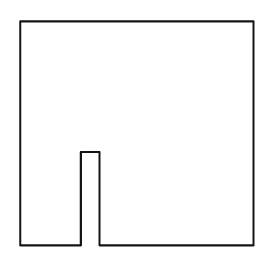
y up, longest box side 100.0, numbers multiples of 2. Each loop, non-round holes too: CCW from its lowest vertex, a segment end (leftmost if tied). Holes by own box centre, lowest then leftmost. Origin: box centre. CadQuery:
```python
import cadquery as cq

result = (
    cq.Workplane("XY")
    .moveTo(-50.0, -48.0)
    .lineTo(-24.0, -48.0)
    .lineTo(-24.0, -8.0)
    .lineTo(-16.0, -8.0)
    .lineTo(-16.0, -48.0)
    .lineTo(50.0, -48.0)
    .lineTo(50.0, 48.0)
    .lineTo(-50.0, 48.0)
    .close()
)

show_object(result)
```